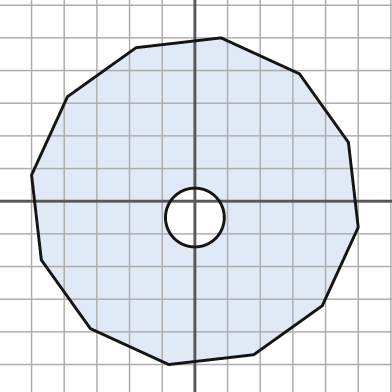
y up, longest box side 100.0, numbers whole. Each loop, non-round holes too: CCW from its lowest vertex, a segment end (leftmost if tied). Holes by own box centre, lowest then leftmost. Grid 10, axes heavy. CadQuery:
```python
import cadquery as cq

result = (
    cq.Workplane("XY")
    .moveTo(-8.0, -50.0)
    .lineTo(18.0, -47.0)
    .lineTo(39.0, -32.0)
    .lineTo(50.0, -8.0)
    .lineTo(47.0, 18.0)
    .lineTo(32.0, 39.0)
    .lineTo(8.0, 50.0)
    .lineTo(-18.0, 47.0)
    .lineTo(-39.0, 32.0)
    .lineTo(-50.0, 8.0)
    .lineTo(-47.0, -18.0)
    .lineTo(-32.0, -39.0)
    .close()
    .moveTo(0.0, -5.0)
    .circle(9.0)
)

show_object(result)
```